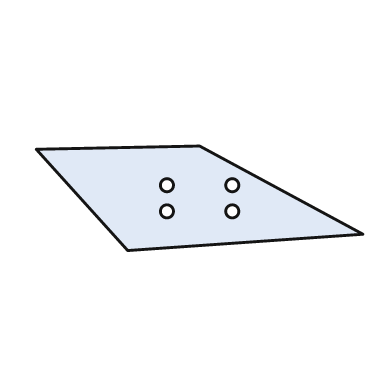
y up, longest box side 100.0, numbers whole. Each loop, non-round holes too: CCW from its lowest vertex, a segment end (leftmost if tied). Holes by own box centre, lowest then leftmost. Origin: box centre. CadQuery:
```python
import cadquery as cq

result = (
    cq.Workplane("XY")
    .moveTo(-22.0, -16.0)
    .lineTo(50.0, -11.0)
    .lineTo(0.0, 16.0)
    .lineTo(-50.0, 15.0)
    .close()
    .moveTo(-10.0, -4.0)
    .circle(2.0)
    .moveTo(10.0, -4.0)
    .circle(2.0)
    .moveTo(-10.0, 4.0)
    .circle(2.0)
    .moveTo(10.0, 4.0)
    .circle(2.0)
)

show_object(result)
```